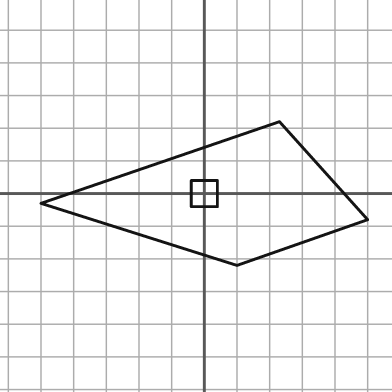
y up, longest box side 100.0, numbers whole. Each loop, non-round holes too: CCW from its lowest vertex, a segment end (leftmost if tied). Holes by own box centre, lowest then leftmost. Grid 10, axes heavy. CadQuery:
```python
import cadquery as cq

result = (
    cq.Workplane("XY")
    .moveTo(10.0, -22.0)
    .lineTo(50.0, -8.0)
    .lineTo(23.0, 22.0)
    .lineTo(-50.0, -3.0)
    .close()
    .moveTo(-4.0, -4.0)
    .lineTo(4.0, -4.0)
    .lineTo(4.0, 4.0)
    .lineTo(-4.0, 4.0)
    .close()
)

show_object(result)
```